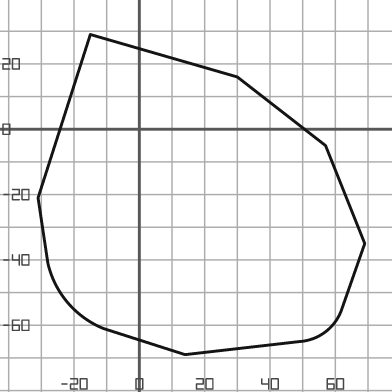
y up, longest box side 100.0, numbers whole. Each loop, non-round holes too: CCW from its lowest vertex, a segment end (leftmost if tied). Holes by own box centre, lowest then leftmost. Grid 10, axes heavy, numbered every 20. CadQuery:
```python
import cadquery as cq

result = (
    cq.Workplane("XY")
    .moveTo(14.0, -69.0)
    .lineTo(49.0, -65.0)
    .threePointArc((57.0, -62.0), (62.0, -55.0))
    .lineTo(69.0, -35.0)
    .lineTo(57.0, -5.0)
    .lineTo(30.0, 16.0)
    .lineTo(-15.0, 29.0)
    .lineTo(-31.0, -21.0)
    .lineTo(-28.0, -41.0)
    .threePointArc((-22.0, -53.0), (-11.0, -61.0))
    .close()
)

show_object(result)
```